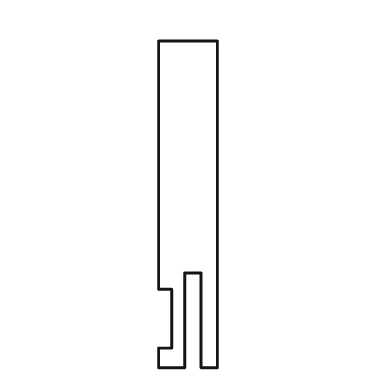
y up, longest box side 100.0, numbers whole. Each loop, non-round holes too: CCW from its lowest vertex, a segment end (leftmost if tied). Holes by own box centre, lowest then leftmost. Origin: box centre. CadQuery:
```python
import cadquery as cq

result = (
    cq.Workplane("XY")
    .moveTo(-9.0, -50.0)
    .lineTo(-1.0, -50.0)
    .lineTo(-1.0, -21.0)
    .lineTo(4.0, -21.0)
    .lineTo(4.0, -50.0)
    .lineTo(9.0, -50.0)
    .lineTo(9.0, 50.0)
    .lineTo(-9.0, 50.0)
    .lineTo(-9.0, -26.0)
    .lineTo(-5.0, -26.0)
    .lineTo(-5.0, -44.0)
    .lineTo(-9.0, -44.0)
    .close()
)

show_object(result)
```